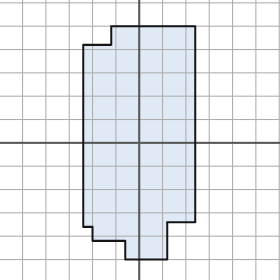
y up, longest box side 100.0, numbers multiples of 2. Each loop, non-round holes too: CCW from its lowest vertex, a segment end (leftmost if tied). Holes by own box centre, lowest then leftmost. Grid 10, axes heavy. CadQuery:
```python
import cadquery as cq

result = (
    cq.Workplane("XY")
    .moveTo(-6.0, -50.0)
    .lineTo(12.0, -50.0)
    .lineTo(12.0, -34.0)
    .lineTo(24.0, -34.0)
    .lineTo(24.0, 50.0)
    .lineTo(-12.0, 50.0)
    .lineTo(-12.0, 42.0)
    .lineTo(-24.0, 42.0)
    .lineTo(-24.0, -36.0)
    .lineTo(-20.0, -36.0)
    .lineTo(-20.0, -42.0)
    .lineTo(-6.0, -42.0)
    .close()
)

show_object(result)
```